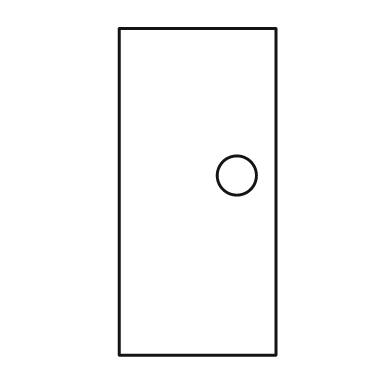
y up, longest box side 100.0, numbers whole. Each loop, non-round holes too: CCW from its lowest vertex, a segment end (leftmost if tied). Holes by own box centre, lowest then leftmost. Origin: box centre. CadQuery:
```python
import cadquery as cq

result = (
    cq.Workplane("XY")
    .moveTo(-24.0, -50.0)
    .lineTo(24.0, -50.0)
    .lineTo(24.0, 50.0)
    .lineTo(-24.0, 50.0)
    .close()
    .moveTo(12.0, 5.0)
    .circle(6.0)
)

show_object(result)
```